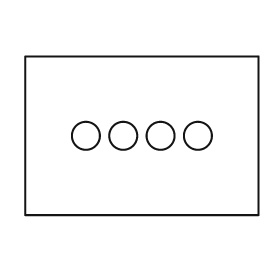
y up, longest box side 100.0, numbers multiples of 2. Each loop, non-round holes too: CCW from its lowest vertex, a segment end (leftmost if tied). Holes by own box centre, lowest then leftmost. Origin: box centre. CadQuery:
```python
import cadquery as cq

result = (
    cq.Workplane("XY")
    .moveTo(-50.0, -34.0)
    .lineTo(50.0, -34.0)
    .lineTo(50.0, 34.0)
    .lineTo(-50.0, 34.0)
    .close()
    .moveTo(-24.0, 0.0)
    .circle(6.0)
    .moveTo(-8.0, 0.0)
    .circle(6.0)
    .moveTo(8.0, 0.0)
    .circle(6.0)
    .moveTo(24.0, 0.0)
    .circle(6.0)
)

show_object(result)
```